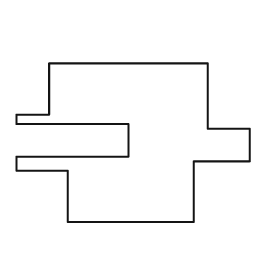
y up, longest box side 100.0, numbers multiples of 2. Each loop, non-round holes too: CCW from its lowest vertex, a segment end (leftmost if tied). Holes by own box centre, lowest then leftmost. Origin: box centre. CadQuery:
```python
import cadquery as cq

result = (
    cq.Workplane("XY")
    .moveTo(-28.0, -34.0)
    .lineTo(26.0, -34.0)
    .lineTo(26.0, -8.0)
    .lineTo(50.0, -8.0)
    .lineTo(50.0, 6.0)
    .lineTo(32.0, 6.0)
    .lineTo(32.0, 34.0)
    .lineTo(-36.0, 34.0)
    .lineTo(-36.0, 12.0)
    .lineTo(-50.0, 12.0)
    .lineTo(-50.0, 8.0)
    .lineTo(-2.0, 8.0)
    .lineTo(-2.0, -6.0)
    .lineTo(-50.0, -6.0)
    .lineTo(-50.0, -12.0)
    .lineTo(-28.0, -12.0)
    .close()
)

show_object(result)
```